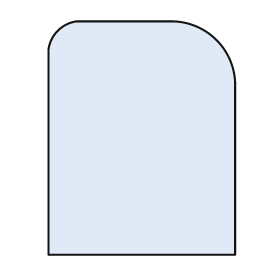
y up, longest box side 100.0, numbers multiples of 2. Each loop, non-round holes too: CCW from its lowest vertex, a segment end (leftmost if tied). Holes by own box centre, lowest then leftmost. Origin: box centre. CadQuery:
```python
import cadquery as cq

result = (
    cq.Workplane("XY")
    .moveTo(-40.0, -50.0)
    .lineTo(40.0, -50.0)
    .lineTo(40.0, 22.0)
    .threePointArc((32.0, 42.0), (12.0, 50.0))
    .lineTo(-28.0, 50.0)
    .threePointArc((-36.0, 46.0), (-40.0, 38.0))
    .close()
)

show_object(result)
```